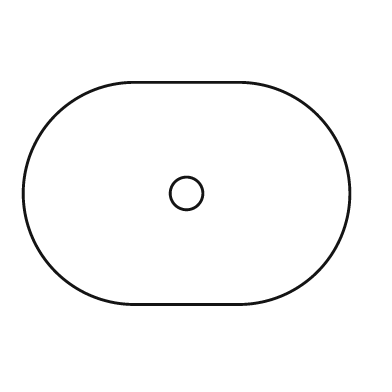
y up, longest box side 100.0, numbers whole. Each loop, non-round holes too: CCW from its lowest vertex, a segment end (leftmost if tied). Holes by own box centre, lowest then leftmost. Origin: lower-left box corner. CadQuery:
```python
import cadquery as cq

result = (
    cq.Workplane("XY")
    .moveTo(34.0, 0.0)
    .lineTo(66.0, 0.0)
    .threePointArc((100.0, 34.0), (66.0, 68.0))
    .lineTo(34.0, 68.0)
    .threePointArc((0.0, 34.0), (34.0, 0.0))
    .close()
    .moveTo(50.0, 34.0)
    .circle(5.0)
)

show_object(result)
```